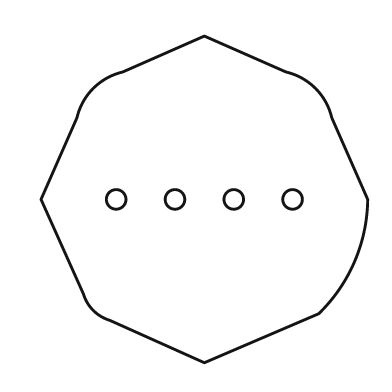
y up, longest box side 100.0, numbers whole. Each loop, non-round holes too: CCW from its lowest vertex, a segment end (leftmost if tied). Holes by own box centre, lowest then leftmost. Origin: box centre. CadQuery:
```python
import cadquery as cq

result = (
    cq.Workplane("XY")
    .moveTo(0.0, -50.0)
    .lineTo(35.0, -35.0)
    .threePointArc((46.0, -19.0), (50.0, 0.0))
    .lineTo(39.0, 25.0)
    .threePointArc((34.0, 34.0), (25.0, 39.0))
    .lineTo(0.0, 50.0)
    .lineTo(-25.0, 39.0)
    .threePointArc((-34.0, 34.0), (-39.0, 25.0))
    .lineTo(-50.0, 0.0)
    .lineTo(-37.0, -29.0)
    .threePointArc((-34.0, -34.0), (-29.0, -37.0))
    .close()
    .moveTo(-27.0, 0.0)
    .circle(3.0)
    .moveTo(-9.0, 0.0)
    .circle(3.0)
    .moveTo(9.0, 0.0)
    .circle(3.0)
    .moveTo(27.0, 0.0)
    .circle(3.0)
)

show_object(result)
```